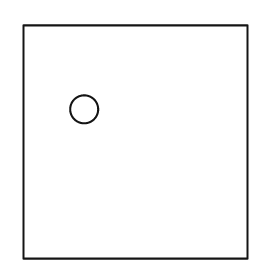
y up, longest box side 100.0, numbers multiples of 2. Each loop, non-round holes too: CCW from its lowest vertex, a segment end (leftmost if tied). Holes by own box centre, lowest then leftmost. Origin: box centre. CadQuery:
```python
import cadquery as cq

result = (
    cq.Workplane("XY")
    .moveTo(-48.0, -50.0)
    .lineTo(48.0, -50.0)
    .lineTo(48.0, 50.0)
    .lineTo(-48.0, 50.0)
    .close()
    .moveTo(-22.0, 14.0)
    .circle(6.0)
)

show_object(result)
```